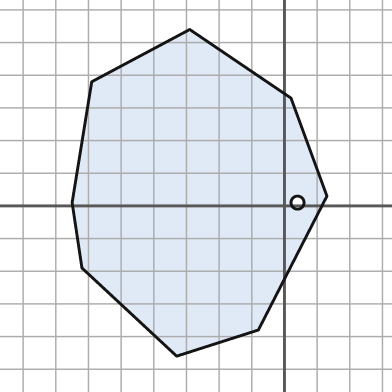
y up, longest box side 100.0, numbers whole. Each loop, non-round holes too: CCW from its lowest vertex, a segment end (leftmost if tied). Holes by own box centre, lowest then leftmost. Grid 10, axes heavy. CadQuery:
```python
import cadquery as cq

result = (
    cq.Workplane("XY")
    .moveTo(-33.0, -46.0)
    .lineTo(-8.0, -38.0)
    .lineTo(13.0, 3.0)
    .lineTo(2.0, 33.0)
    .lineTo(-29.0, 54.0)
    .lineTo(-59.0, 38.0)
    .lineTo(-65.0, 1.0)
    .lineTo(-62.0, -19.0)
    .close()
    .moveTo(4.0, 1.0)
    .circle(2.0)
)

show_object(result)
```